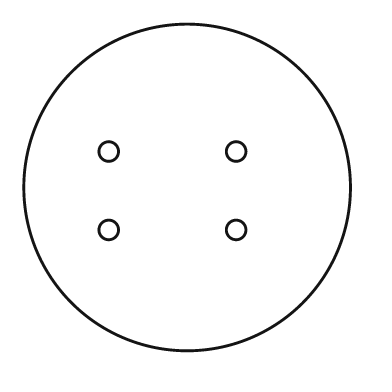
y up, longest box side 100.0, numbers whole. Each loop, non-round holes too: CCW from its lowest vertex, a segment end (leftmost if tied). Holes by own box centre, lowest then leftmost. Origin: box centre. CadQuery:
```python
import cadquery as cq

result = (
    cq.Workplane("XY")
    .moveTo(0.0, 0.0)
    .circle(50.0)
    .moveTo(-24.0, -13.0)
    .circle(3.0)
    .moveTo(15.0, -13.0)
    .circle(3.0)
    .moveTo(-24.0, 11.0)
    .circle(3.0)
    .moveTo(15.0, 11.0)
    .circle(3.0)
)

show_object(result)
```